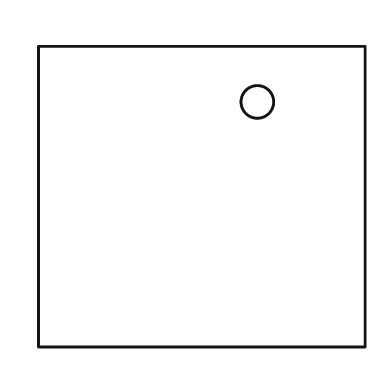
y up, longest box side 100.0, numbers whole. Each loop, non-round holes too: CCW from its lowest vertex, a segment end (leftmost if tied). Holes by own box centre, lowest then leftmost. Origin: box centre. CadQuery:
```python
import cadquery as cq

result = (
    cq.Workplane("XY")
    .moveTo(-50.0, -46.0)
    .lineTo(50.0, -46.0)
    .lineTo(50.0, 46.0)
    .lineTo(-50.0, 46.0)
    .close()
    .moveTo(17.0, 29.0)
    .circle(5.0)
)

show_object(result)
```